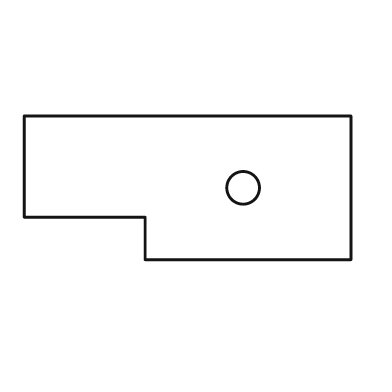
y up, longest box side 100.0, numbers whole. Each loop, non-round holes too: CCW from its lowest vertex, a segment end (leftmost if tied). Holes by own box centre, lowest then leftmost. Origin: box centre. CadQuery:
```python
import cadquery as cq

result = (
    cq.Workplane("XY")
    .moveTo(-13.0, -22.0)
    .lineTo(50.0, -22.0)
    .lineTo(50.0, 22.0)
    .lineTo(-50.0, 22.0)
    .lineTo(-50.0, -9.0)
    .lineTo(-13.0, -9.0)
    .close()
    .moveTo(17.0, 0.0)
    .circle(5.0)
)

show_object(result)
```